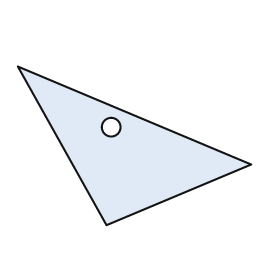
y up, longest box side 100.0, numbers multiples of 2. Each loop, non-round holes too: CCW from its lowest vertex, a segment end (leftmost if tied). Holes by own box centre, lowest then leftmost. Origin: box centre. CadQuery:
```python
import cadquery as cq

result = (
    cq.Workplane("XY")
    .moveTo(-12.0, -34.0)
    .lineTo(50.0, -8.0)
    .lineTo(-50.0, 34.0)
    .close()
    .moveTo(-10.0, 8.0)
    .circle(4.0)
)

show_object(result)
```